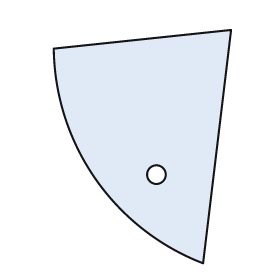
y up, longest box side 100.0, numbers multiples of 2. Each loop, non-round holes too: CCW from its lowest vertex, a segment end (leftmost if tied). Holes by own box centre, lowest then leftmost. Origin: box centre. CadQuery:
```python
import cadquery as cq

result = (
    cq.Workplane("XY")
    .moveTo(26.0, -50.0)
    .lineTo(38.0, 50.0)
    .lineTo(-38.0, 42.0)
    .threePointArc((-20.0, -14.0), (26.0, -50.0))
    .close()
    .moveTo(6.0, -12.0)
    .circle(4.0)
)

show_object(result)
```